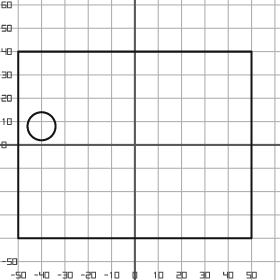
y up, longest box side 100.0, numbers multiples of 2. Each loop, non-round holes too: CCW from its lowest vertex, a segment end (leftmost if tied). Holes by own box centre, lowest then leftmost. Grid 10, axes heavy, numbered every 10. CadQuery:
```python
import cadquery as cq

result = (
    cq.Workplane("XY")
    .moveTo(-50.0, -40.0)
    .lineTo(50.0, -40.0)
    .lineTo(50.0, 40.0)
    .lineTo(-50.0, 40.0)
    .close()
    .moveTo(-40.0, 8.0)
    .circle(6.0)
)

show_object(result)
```